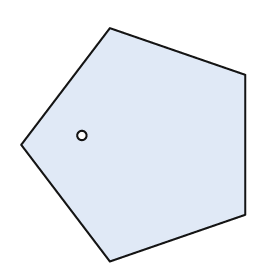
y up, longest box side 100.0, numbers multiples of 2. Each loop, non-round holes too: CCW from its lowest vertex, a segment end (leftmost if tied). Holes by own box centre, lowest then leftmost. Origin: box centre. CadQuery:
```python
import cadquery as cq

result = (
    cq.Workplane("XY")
    .moveTo(-10.0, -50.0)
    .lineTo(48.0, -30.0)
    .lineTo(48.0, 30.0)
    .lineTo(-10.0, 50.0)
    .lineTo(-48.0, 0.0)
    .close()
    .moveTo(-22.0, 4.0)
    .circle(2.0)
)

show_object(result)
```